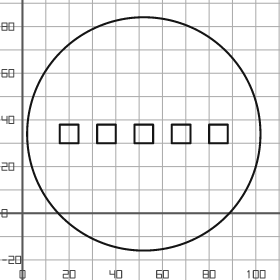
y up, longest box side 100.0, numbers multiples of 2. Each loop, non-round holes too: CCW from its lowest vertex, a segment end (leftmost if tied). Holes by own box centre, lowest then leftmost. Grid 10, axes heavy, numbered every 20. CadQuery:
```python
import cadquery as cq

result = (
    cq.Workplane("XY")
    .moveTo(52.0, 34.0)
    .circle(50.0)
    .moveTo(16.0, 30.0)
    .lineTo(24.0, 30.0)
    .lineTo(24.0, 38.0)
    .lineTo(16.0, 38.0)
    .close()
    .moveTo(32.0, 30.0)
    .lineTo(40.0, 30.0)
    .lineTo(40.0, 38.0)
    .lineTo(32.0, 38.0)
    .close()
    .moveTo(48.0, 30.0)
    .lineTo(56.0, 30.0)
    .lineTo(56.0, 38.0)
    .lineTo(48.0, 38.0)
    .close()
    .moveTo(64.0, 30.0)
    .lineTo(72.0, 30.0)
    .lineTo(72.0, 38.0)
    .lineTo(64.0, 38.0)
    .close()
    .moveTo(80.0, 30.0)
    .lineTo(88.0, 30.0)
    .lineTo(88.0, 38.0)
    .lineTo(80.0, 38.0)
    .close()
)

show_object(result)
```